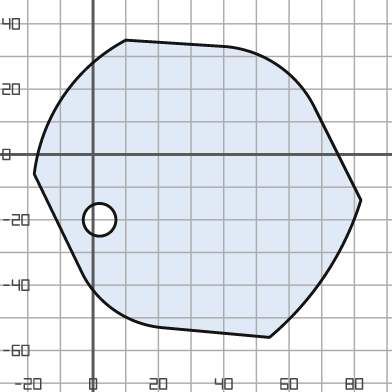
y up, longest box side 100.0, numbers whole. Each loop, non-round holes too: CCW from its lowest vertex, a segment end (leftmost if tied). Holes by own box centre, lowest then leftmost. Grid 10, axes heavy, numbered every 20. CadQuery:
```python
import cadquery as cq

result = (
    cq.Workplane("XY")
    .moveTo(54.0, -56.0)
    .threePointArc((71.0, -37.0), (82.0, -14.0))
    .lineTo(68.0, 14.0)
    .threePointArc((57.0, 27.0), (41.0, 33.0))
    .lineTo(10.0, 35.0)
    .threePointArc((-9.0, 18.0), (-18.0, -6.0))
    .lineTo(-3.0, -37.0)
    .threePointArc((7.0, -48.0), (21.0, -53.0))
    .close()
    .moveTo(2.0, -20.0)
    .circle(5.0)
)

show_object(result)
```